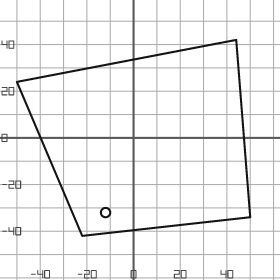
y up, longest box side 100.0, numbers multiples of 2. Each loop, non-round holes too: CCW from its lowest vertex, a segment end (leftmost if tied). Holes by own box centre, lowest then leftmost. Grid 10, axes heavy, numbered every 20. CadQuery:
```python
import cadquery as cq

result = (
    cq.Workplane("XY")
    .moveTo(-22.0, -42.0)
    .lineTo(50.0, -34.0)
    .lineTo(44.0, 42.0)
    .lineTo(-50.0, 24.0)
    .close()
    .moveTo(-12.0, -32.0)
    .circle(2.0)
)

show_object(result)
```